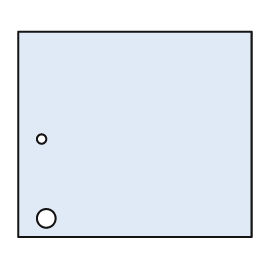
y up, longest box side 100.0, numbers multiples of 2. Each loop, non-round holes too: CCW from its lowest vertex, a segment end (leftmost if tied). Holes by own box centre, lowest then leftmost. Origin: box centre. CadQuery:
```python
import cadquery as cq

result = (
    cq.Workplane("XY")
    .moveTo(-50.0, -44.0)
    .lineTo(50.0, -44.0)
    .lineTo(50.0, 44.0)
    .lineTo(-50.0, 44.0)
    .close()
    .moveTo(-38.0, -36.0)
    .circle(4.0)
    .moveTo(-40.0, -2.0)
    .circle(2.0)
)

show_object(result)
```